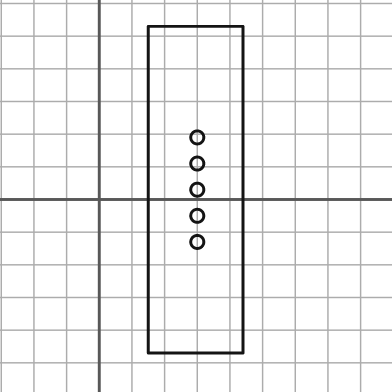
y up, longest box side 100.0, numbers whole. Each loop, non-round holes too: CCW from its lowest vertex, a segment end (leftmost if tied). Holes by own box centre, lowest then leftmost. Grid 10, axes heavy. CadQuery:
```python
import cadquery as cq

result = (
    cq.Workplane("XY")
    .moveTo(15.0, -47.0)
    .lineTo(44.0, -47.0)
    .lineTo(44.0, 53.0)
    .lineTo(15.0, 53.0)
    .close()
    .moveTo(30.0, -13.0)
    .circle(2.0)
    .moveTo(30.0, -5.0)
    .circle(2.0)
    .moveTo(30.0, 3.0)
    .circle(2.0)
    .moveTo(30.0, 11.0)
    .circle(2.0)
    .moveTo(30.0, 19.0)
    .circle(2.0)
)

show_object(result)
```